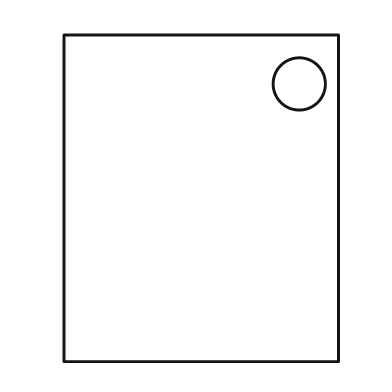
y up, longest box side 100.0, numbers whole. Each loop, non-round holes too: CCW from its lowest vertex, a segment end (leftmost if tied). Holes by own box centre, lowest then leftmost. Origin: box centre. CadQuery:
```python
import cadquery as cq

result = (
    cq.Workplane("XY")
    .moveTo(-42.0, -50.0)
    .lineTo(42.0, -50.0)
    .lineTo(42.0, 50.0)
    .lineTo(-42.0, 50.0)
    .close()
    .moveTo(30.0, 35.0)
    .circle(8.0)
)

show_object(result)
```